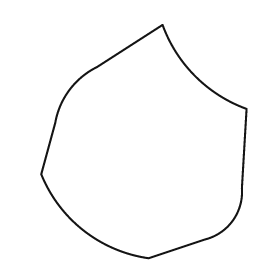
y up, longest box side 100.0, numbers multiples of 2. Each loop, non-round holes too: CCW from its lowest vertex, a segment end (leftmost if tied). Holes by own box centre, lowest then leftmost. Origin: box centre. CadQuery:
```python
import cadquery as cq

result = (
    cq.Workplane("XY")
    .moveTo(2.0, -50.0)
    .lineTo(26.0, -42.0)
    .threePointArc((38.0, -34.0), (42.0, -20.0))
    .lineTo(44.0, 14.0)
    .threePointArc((22.0, 28.0), (8.0, 50.0))
    .lineTo(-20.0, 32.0)
    .threePointArc((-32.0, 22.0), (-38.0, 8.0))
    .lineTo(-44.0, -14.0)
    .threePointArc((-26.0, -38.0), (2.0, -50.0))
    .close()
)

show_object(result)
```